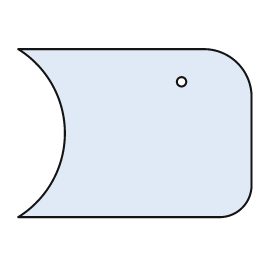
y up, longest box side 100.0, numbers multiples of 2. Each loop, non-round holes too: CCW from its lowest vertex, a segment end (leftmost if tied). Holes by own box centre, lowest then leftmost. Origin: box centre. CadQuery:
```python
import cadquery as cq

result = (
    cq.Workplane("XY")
    .moveTo(-50.0, -36.0)
    .lineTo(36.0, -36.0)
    .threePointArc((46.0, -32.0), (50.0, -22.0))
    .lineTo(50.0, 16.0)
    .threePointArc((44.0, 30.0), (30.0, 36.0))
    .lineTo(-50.0, 36.0)
    .threePointArc((-30.0, 0.0), (-50.0, -36.0))
    .close()
    .moveTo(20.0, 22.0)
    .circle(2.0)
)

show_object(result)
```